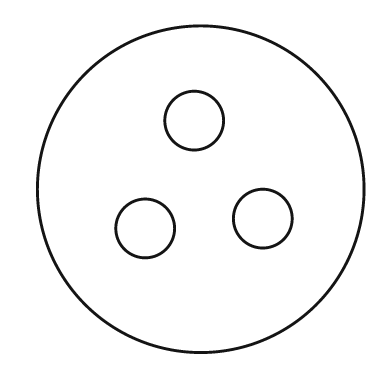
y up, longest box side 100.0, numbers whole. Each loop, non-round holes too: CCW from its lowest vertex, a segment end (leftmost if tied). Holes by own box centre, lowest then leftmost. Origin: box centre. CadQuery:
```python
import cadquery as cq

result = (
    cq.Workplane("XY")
    .moveTo(0.0, 0.0)
    .circle(50.0)
    .moveTo(-17.0, -12.0)
    .circle(9.0)
    .moveTo(19.0, -9.0)
    .circle(9.0)
    .moveTo(-2.0, 21.0)
    .circle(9.0)
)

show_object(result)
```